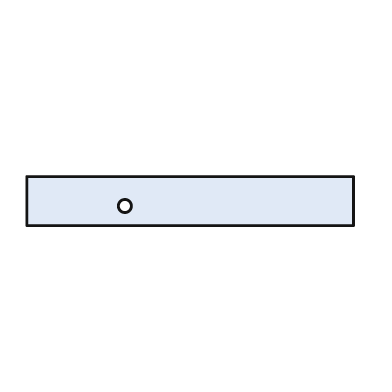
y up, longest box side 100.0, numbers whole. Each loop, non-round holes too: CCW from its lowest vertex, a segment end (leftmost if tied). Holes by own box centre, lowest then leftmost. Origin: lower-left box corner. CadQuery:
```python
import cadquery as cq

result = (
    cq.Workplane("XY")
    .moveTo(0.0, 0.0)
    .lineTo(100.0, 0.0)
    .lineTo(100.0, 15.0)
    .lineTo(0.0, 15.0)
    .close()
    .moveTo(30.0, 6.0)
    .circle(2.0)
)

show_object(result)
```